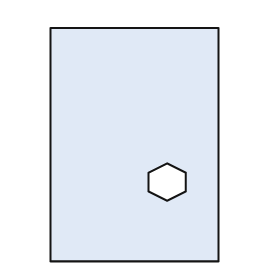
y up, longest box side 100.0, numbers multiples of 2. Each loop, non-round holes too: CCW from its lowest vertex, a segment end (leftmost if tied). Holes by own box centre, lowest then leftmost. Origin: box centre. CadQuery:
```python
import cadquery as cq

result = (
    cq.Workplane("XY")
    .moveTo(-36.0, -50.0)
    .lineTo(36.0, -50.0)
    .lineTo(36.0, 50.0)
    .lineTo(-36.0, 50.0)
    .close()
    .moveTo(14.0, -24.0)
    .lineTo(22.0, -20.0)
    .lineTo(22.0, -12.0)
    .lineTo(14.0, -8.0)
    .lineTo(6.0, -12.0)
    .lineTo(6.0, -20.0)
    .close()
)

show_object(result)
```